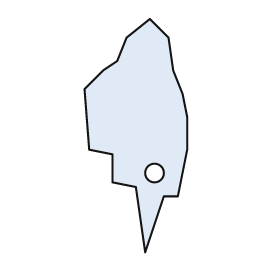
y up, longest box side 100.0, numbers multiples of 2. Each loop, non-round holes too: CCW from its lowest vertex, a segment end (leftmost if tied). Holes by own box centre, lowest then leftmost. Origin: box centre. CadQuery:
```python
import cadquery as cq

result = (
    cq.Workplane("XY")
    .moveTo(4.0, -50.0)
    .lineTo(12.0, -26.0)
    .lineTo(18.0, -26.0)
    .lineTo(22.0, -6.0)
    .lineTo(22.0, 8.0)
    .lineTo(20.0, 18.0)
    .lineTo(16.0, 28.0)
    .lineTo(14.0, 42.0)
    .lineTo(6.0, 50.0)
    .lineTo(-4.0, 42.0)
    .lineTo(-8.0, 32.0)
    .lineTo(-14.0, 28.0)
    .lineTo(-22.0, 20.0)
    .lineTo(-20.0, -6.0)
    .lineTo(-10.0, -8.0)
    .lineTo(-10.0, -20.0)
    .lineTo(0.0, -22.0)
    .close()
    .moveTo(8.0, -16.0)
    .circle(4.0)
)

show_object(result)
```